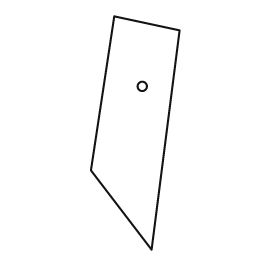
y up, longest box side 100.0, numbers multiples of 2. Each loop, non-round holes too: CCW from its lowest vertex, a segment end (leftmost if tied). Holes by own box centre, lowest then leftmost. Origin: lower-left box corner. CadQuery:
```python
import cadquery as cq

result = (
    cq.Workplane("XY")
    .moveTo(26.0, 0.0)
    .lineTo(38.0, 94.0)
    .lineTo(10.0, 100.0)
    .lineTo(0.0, 34.0)
    .close()
    .moveTo(22.0, 70.0)
    .circle(2.0)
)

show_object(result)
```